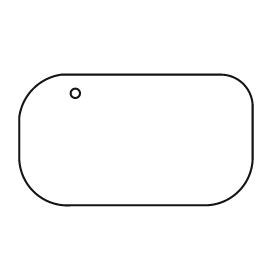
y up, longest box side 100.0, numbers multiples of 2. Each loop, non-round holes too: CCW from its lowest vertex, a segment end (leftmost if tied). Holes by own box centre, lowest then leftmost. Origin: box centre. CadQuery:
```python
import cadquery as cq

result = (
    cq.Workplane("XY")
    .moveTo(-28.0, -28.0)
    .lineTo(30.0, -28.0)
    .threePointArc((44.0, -22.0), (50.0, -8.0))
    .lineTo(50.0, 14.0)
    .threePointArc((46.0, 24.0), (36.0, 28.0))
    .lineTo(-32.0, 28.0)
    .threePointArc((-44.0, 22.0), (-50.0, 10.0))
    .lineTo(-50.0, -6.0)
    .threePointArc((-44.0, -22.0), (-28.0, -28.0))
    .close()
    .moveTo(-26.0, 20.0)
    .circle(2.0)
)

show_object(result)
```